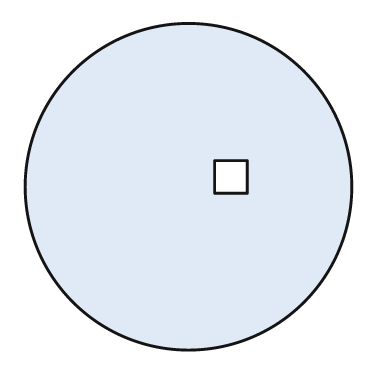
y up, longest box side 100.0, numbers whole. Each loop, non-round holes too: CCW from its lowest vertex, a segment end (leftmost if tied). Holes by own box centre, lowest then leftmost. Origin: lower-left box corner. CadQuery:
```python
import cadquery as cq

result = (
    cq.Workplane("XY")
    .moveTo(50.0, 50.0)
    .circle(50.0)
    .moveTo(58.0, 48.0)
    .lineTo(68.0, 48.0)
    .lineTo(68.0, 58.0)
    .lineTo(58.0, 58.0)
    .close()
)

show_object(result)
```